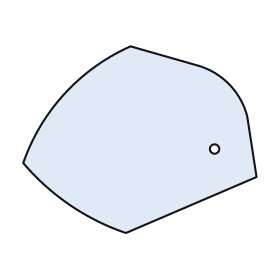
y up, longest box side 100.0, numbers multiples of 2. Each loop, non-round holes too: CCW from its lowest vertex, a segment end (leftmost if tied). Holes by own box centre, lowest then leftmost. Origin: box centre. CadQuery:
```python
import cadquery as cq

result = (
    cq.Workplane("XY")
    .moveTo(-6.0, -40.0)
    .lineTo(50.0, -16.0)
    .lineTo(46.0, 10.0)
    .threePointArc((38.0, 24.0), (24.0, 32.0))
    .lineTo(-4.0, 40.0)
    .threePointArc((-32.0, 20.0), (-50.0, -10.0))
    .threePointArc((-30.0, -28.0), (-6.0, -40.0))
    .close()
    .moveTo(32.0, -4.0)
    .circle(2.0)
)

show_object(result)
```